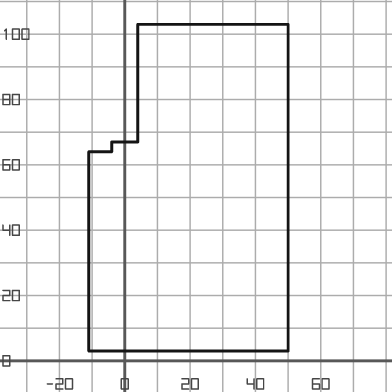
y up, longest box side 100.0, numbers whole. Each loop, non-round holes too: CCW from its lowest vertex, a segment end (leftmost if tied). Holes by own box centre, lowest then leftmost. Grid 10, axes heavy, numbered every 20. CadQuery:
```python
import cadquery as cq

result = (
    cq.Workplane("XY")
    .moveTo(-11.0, 3.0)
    .lineTo(50.0, 3.0)
    .lineTo(50.0, 103.0)
    .lineTo(4.0, 103.0)
    .lineTo(4.0, 67.0)
    .lineTo(-4.0, 67.0)
    .lineTo(-4.0, 64.0)
    .lineTo(-11.0, 64.0)
    .close()
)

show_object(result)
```